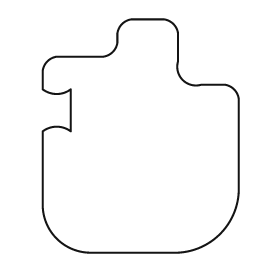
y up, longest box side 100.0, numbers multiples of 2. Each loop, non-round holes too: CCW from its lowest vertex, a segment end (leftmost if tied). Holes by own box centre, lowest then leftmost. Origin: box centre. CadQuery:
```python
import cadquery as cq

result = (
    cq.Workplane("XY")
    .moveTo(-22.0, -50.0)
    .lineTo(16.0, -50.0)
    .threePointArc((34.0, -42.0), (42.0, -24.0))
    .lineTo(42.0, 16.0)
    .threePointArc((40.0, 20.0), (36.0, 22.0))
    .lineTo(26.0, 22.0)
    .threePointArc((18.0, 24.0), (16.0, 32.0))
    .lineTo(16.0, 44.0)
    .threePointArc((14.0, 48.0), (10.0, 50.0))
    .lineTo(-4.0, 50.0)
    .threePointArc((-8.0, 48.0), (-10.0, 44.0))
    .lineTo(-10.0, 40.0)
    .threePointArc((-12.0, 36.0), (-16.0, 34.0))
    .lineTo(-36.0, 34.0)
    .threePointArc((-40.0, 32.0), (-42.0, 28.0))
    .lineTo(-42.0, 20.0)
    .threePointArc((-36.0, 18.0), (-30.0, 20.0))
    .lineTo(-30.0, 2.0)
    .threePointArc((-36.0, 4.0), (-42.0, 2.0))
    .lineTo(-42.0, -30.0)
    .threePointArc((-36.0, -44.0), (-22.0, -50.0))
    .close()
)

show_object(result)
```